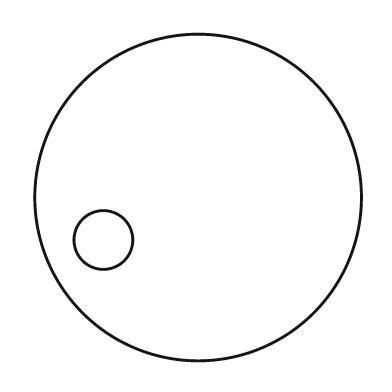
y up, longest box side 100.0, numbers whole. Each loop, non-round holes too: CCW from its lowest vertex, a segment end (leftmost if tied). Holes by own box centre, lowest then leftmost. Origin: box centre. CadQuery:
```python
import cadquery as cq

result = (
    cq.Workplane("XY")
    .moveTo(0.0, 0.0)
    .circle(50.0)
    .moveTo(-29.0, -13.0)
    .circle(9.0)
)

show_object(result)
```